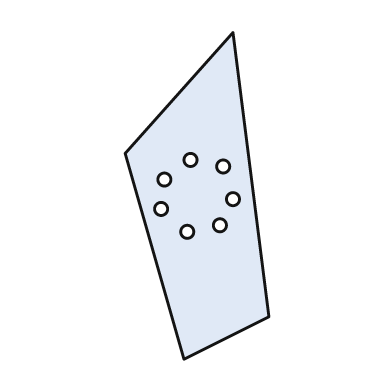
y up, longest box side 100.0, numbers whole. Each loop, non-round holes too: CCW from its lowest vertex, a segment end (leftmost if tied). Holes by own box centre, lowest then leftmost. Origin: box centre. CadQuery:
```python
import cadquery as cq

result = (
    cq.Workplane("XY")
    .moveTo(-4.0, -50.0)
    .lineTo(22.0, -37.0)
    .lineTo(11.0, 50.0)
    .lineTo(-22.0, 13.0)
    .close()
    .moveTo(-3.0, -11.0)
    .circle(2.0)
    .moveTo(7.0, -9.0)
    .circle(2.0)
    .moveTo(-11.0, -4.0)
    .circle(2.0)
    .moveTo(11.0, -1.0)
    .circle(2.0)
    .moveTo(-10.0, 5.0)
    .circle(2.0)
    .moveTo(8.0, 9.0)
    .circle(2.0)
    .moveTo(-2.0, 11.0)
    .circle(2.0)
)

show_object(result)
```